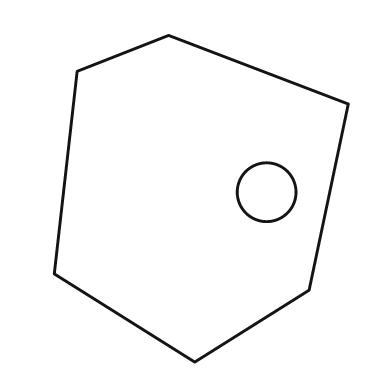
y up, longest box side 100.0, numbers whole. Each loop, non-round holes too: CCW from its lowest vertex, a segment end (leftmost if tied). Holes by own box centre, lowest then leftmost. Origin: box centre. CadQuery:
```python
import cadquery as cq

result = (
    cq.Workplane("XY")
    .moveTo(-2.0, -50.0)
    .lineTo(33.0, -28.0)
    .lineTo(45.0, 29.0)
    .lineTo(-10.0, 50.0)
    .lineTo(-38.0, 39.0)
    .lineTo(-45.0, -23.0)
    .close()
    .moveTo(20.0, 2.0)
    .circle(9.0)
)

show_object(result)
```